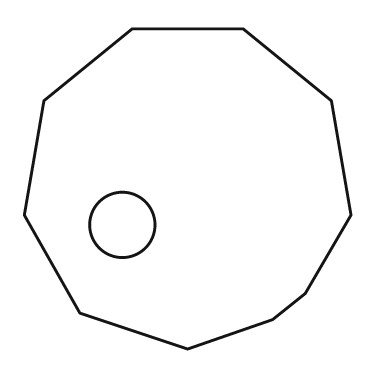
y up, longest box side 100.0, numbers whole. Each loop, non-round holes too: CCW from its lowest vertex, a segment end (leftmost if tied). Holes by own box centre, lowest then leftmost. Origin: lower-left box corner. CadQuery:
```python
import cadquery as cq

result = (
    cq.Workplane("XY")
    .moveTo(50.0, 0.0)
    .lineTo(76.0, 9.0)
    .lineTo(86.0, 17.0)
    .lineTo(100.0, 41.0)
    .lineTo(94.0, 76.0)
    .lineTo(67.0, 98.0)
    .lineTo(33.0, 98.0)
    .lineTo(6.0, 76.0)
    .lineTo(0.0, 41.0)
    .lineTo(17.0, 11.0)
    .close()
    .moveTo(30.0, 38.0)
    .circle(10.0)
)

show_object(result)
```